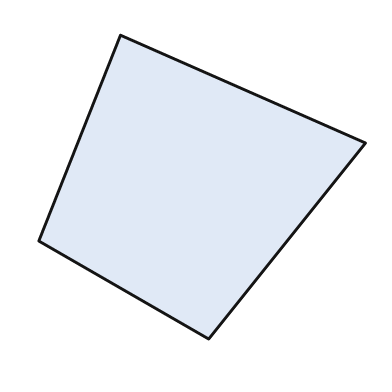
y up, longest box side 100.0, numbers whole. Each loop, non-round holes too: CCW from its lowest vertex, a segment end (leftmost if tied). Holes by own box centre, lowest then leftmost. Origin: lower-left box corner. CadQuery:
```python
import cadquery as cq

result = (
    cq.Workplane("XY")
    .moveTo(52.0, 0.0)
    .lineTo(100.0, 60.0)
    .lineTo(25.0, 93.0)
    .lineTo(0.0, 30.0)
    .close()
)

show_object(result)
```